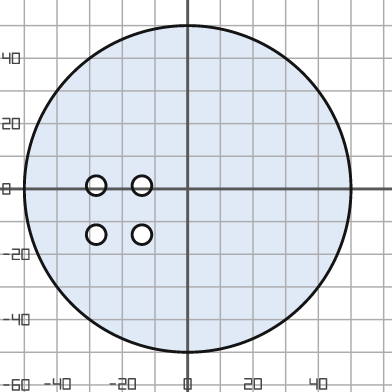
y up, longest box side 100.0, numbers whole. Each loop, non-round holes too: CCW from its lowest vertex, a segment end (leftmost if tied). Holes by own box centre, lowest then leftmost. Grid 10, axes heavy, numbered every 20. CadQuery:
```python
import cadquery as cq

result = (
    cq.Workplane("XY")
    .moveTo(0.0, 0.0)
    .circle(50.0)
    .moveTo(-28.0, -14.0)
    .circle(3.0)
    .moveTo(-14.0, -14.0)
    .circle(3.0)
    .moveTo(-28.0, 1.0)
    .circle(3.0)
    .moveTo(-14.0, 1.0)
    .circle(3.0)
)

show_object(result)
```